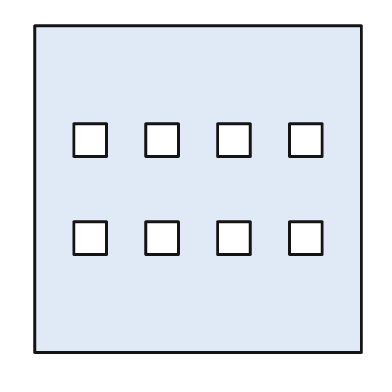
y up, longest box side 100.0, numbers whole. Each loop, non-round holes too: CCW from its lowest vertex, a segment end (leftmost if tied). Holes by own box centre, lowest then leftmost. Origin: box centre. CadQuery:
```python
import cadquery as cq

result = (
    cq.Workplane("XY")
    .moveTo(-50.0, -50.0)
    .lineTo(50.0, -50.0)
    .lineTo(50.0, 50.0)
    .lineTo(-50.0, 50.0)
    .close()
    .moveTo(-38.0, -20.0)
    .lineTo(-28.0, -20.0)
    .lineTo(-28.0, -10.0)
    .lineTo(-38.0, -10.0)
    .close()
    .moveTo(-16.0, -20.0)
    .lineTo(-6.0, -20.0)
    .lineTo(-6.0, -10.0)
    .lineTo(-16.0, -10.0)
    .close()
    .moveTo(6.0, -20.0)
    .lineTo(16.0, -20.0)
    .lineTo(16.0, -10.0)
    .lineTo(6.0, -10.0)
    .close()
    .moveTo(28.0, -20.0)
    .lineTo(38.0, -20.0)
    .lineTo(38.0, -10.0)
    .lineTo(28.0, -10.0)
    .close()
    .moveTo(-38.0, 10.0)
    .lineTo(-28.0, 10.0)
    .lineTo(-28.0, 20.0)
    .lineTo(-38.0, 20.0)
    .close()
    .moveTo(-16.0, 10.0)
    .lineTo(-6.0, 10.0)
    .lineTo(-6.0, 20.0)
    .lineTo(-16.0, 20.0)
    .close()
    .moveTo(6.0, 10.0)
    .lineTo(16.0, 10.0)
    .lineTo(16.0, 20.0)
    .lineTo(6.0, 20.0)
    .close()
    .moveTo(28.0, 10.0)
    .lineTo(38.0, 10.0)
    .lineTo(38.0, 20.0)
    .lineTo(28.0, 20.0)
    .close()
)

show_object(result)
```